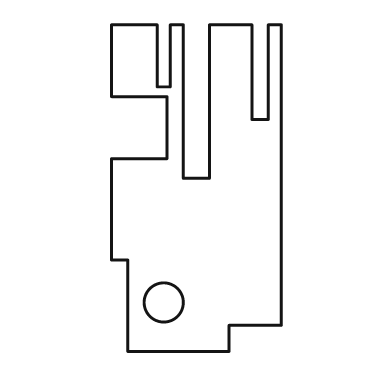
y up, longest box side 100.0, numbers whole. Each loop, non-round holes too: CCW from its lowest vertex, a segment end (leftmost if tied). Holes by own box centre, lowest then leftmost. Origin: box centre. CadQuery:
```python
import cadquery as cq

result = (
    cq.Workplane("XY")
    .moveTo(-21.0, -50.0)
    .lineTo(10.0, -50.0)
    .lineTo(10.0, -42.0)
    .lineTo(26.0, -42.0)
    .lineTo(26.0, 50.0)
    .lineTo(22.0, 50.0)
    .lineTo(22.0, 21.0)
    .lineTo(17.0, 21.0)
    .lineTo(17.0, 50.0)
    .lineTo(4.0, 50.0)
    .lineTo(4.0, 3.0)
    .lineTo(-4.0, 3.0)
    .lineTo(-4.0, 50.0)
    .lineTo(-8.0, 50.0)
    .lineTo(-8.0, 31.0)
    .lineTo(-12.0, 31.0)
    .lineTo(-12.0, 50.0)
    .lineTo(-26.0, 50.0)
    .lineTo(-26.0, 28.0)
    .lineTo(-9.0, 28.0)
    .lineTo(-9.0, 9.0)
    .lineTo(-26.0, 9.0)
    .lineTo(-26.0, -22.0)
    .lineTo(-21.0, -22.0)
    .close()
    .moveTo(-10.0, -35.0)
    .circle(6.0)
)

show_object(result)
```